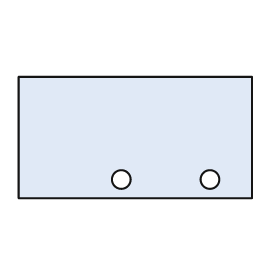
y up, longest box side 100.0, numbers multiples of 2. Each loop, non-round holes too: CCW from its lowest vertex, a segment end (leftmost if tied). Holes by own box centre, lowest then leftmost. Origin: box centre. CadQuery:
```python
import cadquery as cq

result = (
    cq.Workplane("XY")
    .moveTo(-50.0, -26.0)
    .lineTo(50.0, -26.0)
    .lineTo(50.0, 26.0)
    .lineTo(-50.0, 26.0)
    .close()
    .moveTo(-6.0, -18.0)
    .circle(4.0)
    .moveTo(32.0, -18.0)
    .circle(4.0)
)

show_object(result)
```